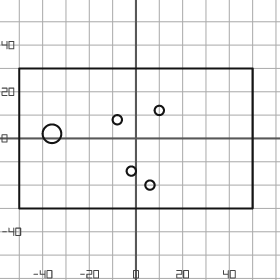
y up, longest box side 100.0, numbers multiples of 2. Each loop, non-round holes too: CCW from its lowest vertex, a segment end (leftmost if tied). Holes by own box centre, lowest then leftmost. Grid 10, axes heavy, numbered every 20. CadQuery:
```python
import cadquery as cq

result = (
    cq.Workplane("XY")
    .moveTo(-50.0, -30.0)
    .lineTo(50.0, -30.0)
    .lineTo(50.0, 30.0)
    .lineTo(-50.0, 30.0)
    .close()
    .moveTo(6.0, -20.0)
    .circle(2.0)
    .moveTo(-2.0, -14.0)
    .circle(2.0)
    .moveTo(-36.0, 2.0)
    .circle(4.0)
    .moveTo(-8.0, 8.0)
    .circle(2.0)
    .moveTo(10.0, 12.0)
    .circle(2.0)
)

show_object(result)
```